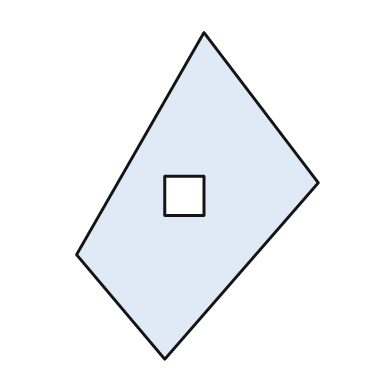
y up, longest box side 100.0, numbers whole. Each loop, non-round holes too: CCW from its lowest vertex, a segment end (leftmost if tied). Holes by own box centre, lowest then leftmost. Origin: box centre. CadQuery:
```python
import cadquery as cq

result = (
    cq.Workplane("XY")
    .moveTo(-10.0, -50.0)
    .lineTo(37.0, 4.0)
    .lineTo(2.0, 50.0)
    .lineTo(-37.0, -18.0)
    .close()
    .moveTo(-10.0, -6.0)
    .lineTo(2.0, -6.0)
    .lineTo(2.0, 6.0)
    .lineTo(-10.0, 6.0)
    .close()
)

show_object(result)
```